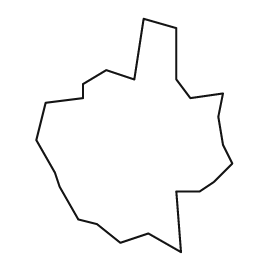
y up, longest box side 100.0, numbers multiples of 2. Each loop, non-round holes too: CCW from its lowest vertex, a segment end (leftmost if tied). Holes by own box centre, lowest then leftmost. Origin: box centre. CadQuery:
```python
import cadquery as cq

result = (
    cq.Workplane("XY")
    .moveTo(20.0, -50.0)
    .lineTo(18.0, -24.0)
    .lineTo(28.0, -24.0)
    .lineTo(34.0, -20.0)
    .lineTo(42.0, -12.0)
    .lineTo(38.0, -4.0)
    .lineTo(36.0, 8.0)
    .lineTo(38.0, 18.0)
    .lineTo(24.0, 16.0)
    .lineTo(18.0, 24.0)
    .lineTo(18.0, 46.0)
    .lineTo(4.0, 50.0)
    .lineTo(0.0, 24.0)
    .lineTo(-12.0, 28.0)
    .lineTo(-22.0, 22.0)
    .lineTo(-22.0, 16.0)
    .lineTo(-38.0, 14.0)
    .lineTo(-42.0, -2.0)
    .lineTo(-34.0, -16.0)
    .lineTo(-32.0, -22.0)
    .lineTo(-24.0, -36.0)
    .lineTo(-16.0, -38.0)
    .lineTo(-6.0, -46.0)
    .lineTo(6.0, -42.0)
    .close()
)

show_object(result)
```